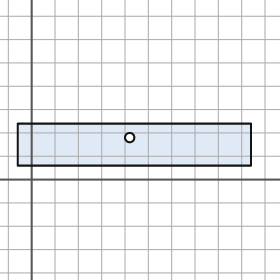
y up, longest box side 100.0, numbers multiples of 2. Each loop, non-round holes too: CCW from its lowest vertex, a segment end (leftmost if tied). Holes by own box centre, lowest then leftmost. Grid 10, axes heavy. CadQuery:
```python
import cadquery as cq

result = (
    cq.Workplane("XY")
    .moveTo(-6.0, 6.0)
    .lineTo(94.0, 6.0)
    .lineTo(94.0, 24.0)
    .lineTo(-6.0, 24.0)
    .close()
    .moveTo(42.0, 18.0)
    .circle(2.0)
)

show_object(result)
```